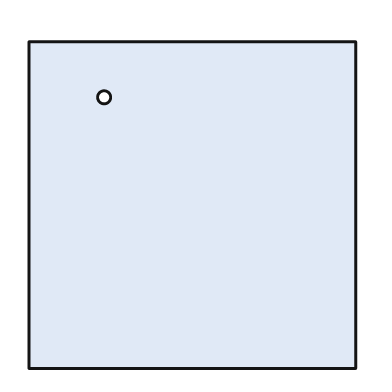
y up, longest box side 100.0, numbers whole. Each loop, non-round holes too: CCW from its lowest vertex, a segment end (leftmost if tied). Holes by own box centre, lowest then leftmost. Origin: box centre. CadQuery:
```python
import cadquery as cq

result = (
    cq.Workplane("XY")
    .moveTo(-50.0, -50.0)
    .lineTo(50.0, -50.0)
    .lineTo(50.0, 50.0)
    .lineTo(-50.0, 50.0)
    .close()
    .moveTo(-27.0, 33.0)
    .circle(2.0)
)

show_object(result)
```